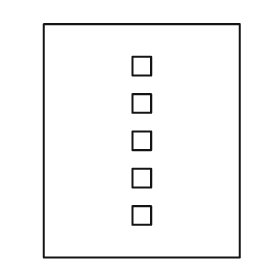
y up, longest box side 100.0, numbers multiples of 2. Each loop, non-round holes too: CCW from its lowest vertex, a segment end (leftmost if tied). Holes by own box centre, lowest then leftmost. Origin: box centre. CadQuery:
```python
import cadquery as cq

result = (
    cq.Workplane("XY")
    .moveTo(-42.0, -50.0)
    .lineTo(42.0, -50.0)
    .lineTo(42.0, 50.0)
    .lineTo(-42.0, 50.0)
    .close()
    .moveTo(-4.0, -36.0)
    .lineTo(4.0, -36.0)
    .lineTo(4.0, -28.0)
    .lineTo(-4.0, -28.0)
    .close()
    .moveTo(-4.0, -20.0)
    .lineTo(4.0, -20.0)
    .lineTo(4.0, -12.0)
    .lineTo(-4.0, -12.0)
    .close()
    .moveTo(-4.0, -4.0)
    .lineTo(4.0, -4.0)
    .lineTo(4.0, 4.0)
    .lineTo(-4.0, 4.0)
    .close()
    .moveTo(-4.0, 12.0)
    .lineTo(4.0, 12.0)
    .lineTo(4.0, 20.0)
    .lineTo(-4.0, 20.0)
    .close()
    .moveTo(-4.0, 28.0)
    .lineTo(4.0, 28.0)
    .lineTo(4.0, 36.0)
    .lineTo(-4.0, 36.0)
    .close()
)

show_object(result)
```